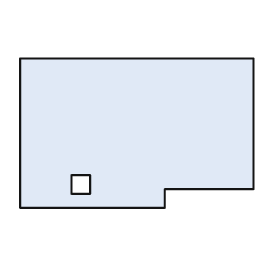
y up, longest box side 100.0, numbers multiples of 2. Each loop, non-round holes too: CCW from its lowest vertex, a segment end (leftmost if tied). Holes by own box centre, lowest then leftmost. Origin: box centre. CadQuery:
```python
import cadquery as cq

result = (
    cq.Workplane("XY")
    .moveTo(-50.0, -32.0)
    .lineTo(12.0, -32.0)
    .lineTo(12.0, -24.0)
    .lineTo(50.0, -24.0)
    .lineTo(50.0, 32.0)
    .lineTo(-50.0, 32.0)
    .close()
    .moveTo(-28.0, -26.0)
    .lineTo(-20.0, -26.0)
    .lineTo(-20.0, -18.0)
    .lineTo(-28.0, -18.0)
    .close()
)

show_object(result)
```